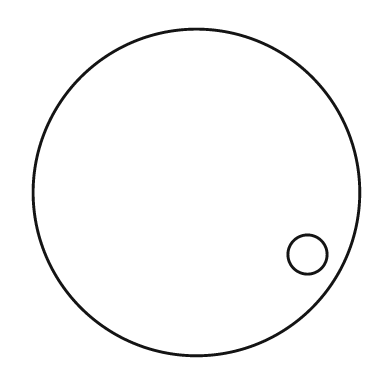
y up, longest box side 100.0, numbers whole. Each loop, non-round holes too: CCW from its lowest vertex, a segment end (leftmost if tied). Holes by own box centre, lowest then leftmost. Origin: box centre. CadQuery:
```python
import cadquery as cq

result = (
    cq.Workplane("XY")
    .moveTo(0.0, 0.0)
    .circle(50.0)
    .moveTo(34.0, -19.0)
    .circle(6.0)
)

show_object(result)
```